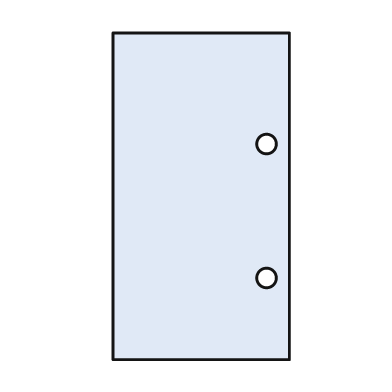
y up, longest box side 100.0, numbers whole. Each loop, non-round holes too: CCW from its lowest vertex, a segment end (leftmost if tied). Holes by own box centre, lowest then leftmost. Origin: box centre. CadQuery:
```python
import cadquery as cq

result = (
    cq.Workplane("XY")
    .moveTo(-27.0, -50.0)
    .lineTo(27.0, -50.0)
    .lineTo(27.0, 50.0)
    .lineTo(-27.0, 50.0)
    .close()
    .moveTo(20.0, -25.0)
    .circle(3.0)
    .moveTo(20.0, 16.0)
    .circle(3.0)
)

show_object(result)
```